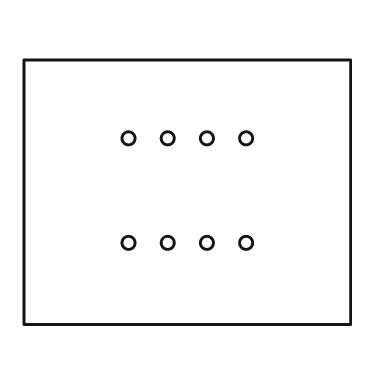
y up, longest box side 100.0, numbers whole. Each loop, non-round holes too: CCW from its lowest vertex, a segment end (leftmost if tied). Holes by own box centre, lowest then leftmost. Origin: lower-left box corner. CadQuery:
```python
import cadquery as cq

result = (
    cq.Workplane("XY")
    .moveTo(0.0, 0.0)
    .lineTo(100.0, 0.0)
    .lineTo(100.0, 81.0)
    .lineTo(0.0, 81.0)
    .close()
    .moveTo(32.0, 25.0)
    .circle(2.0)
    .moveTo(44.0, 25.0)
    .circle(2.0)
    .moveTo(56.0, 25.0)
    .circle(2.0)
    .moveTo(68.0, 25.0)
    .circle(2.0)
    .moveTo(32.0, 57.0)
    .circle(2.0)
    .moveTo(44.0, 57.0)
    .circle(2.0)
    .moveTo(56.0, 57.0)
    .circle(2.0)
    .moveTo(68.0, 57.0)
    .circle(2.0)
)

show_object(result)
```